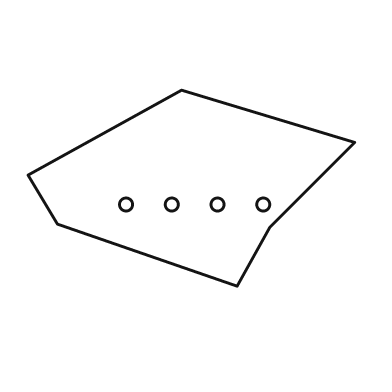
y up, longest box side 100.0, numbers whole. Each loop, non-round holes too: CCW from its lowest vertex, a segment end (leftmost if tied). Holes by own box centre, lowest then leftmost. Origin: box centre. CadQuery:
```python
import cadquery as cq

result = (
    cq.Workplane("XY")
    .moveTo(14.0, -30.0)
    .lineTo(24.0, -12.0)
    .lineTo(50.0, 14.0)
    .lineTo(-3.0, 30.0)
    .lineTo(-50.0, 4.0)
    .lineTo(-41.0, -11.0)
    .close()
    .moveTo(-20.0, -5.0)
    .circle(2.0)
    .moveTo(-6.0, -5.0)
    .circle(2.0)
    .moveTo(8.0, -5.0)
    .circle(2.0)
    .moveTo(22.0, -5.0)
    .circle(2.0)
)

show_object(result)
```